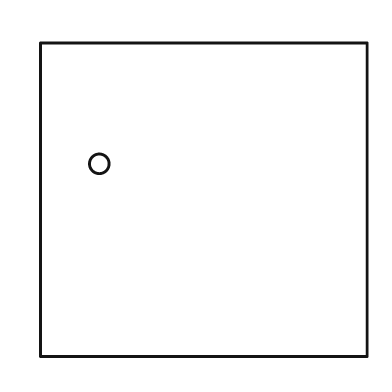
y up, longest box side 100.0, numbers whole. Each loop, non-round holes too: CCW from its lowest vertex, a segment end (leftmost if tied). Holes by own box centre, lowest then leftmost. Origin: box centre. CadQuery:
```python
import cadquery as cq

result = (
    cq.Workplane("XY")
    .moveTo(-50.0, -48.0)
    .lineTo(50.0, -48.0)
    .lineTo(50.0, 48.0)
    .lineTo(-50.0, 48.0)
    .close()
    .moveTo(-32.0, 11.0)
    .circle(3.0)
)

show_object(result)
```